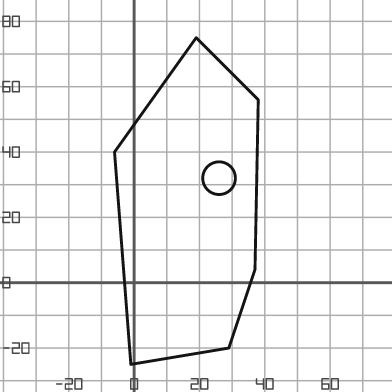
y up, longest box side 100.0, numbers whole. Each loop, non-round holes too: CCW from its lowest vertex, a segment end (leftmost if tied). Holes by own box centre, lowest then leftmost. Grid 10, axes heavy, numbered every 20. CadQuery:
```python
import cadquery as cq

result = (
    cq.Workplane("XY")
    .moveTo(-1.0, -25.0)
    .lineTo(29.0, -20.0)
    .lineTo(37.0, 4.0)
    .lineTo(38.0, 56.0)
    .lineTo(19.0, 75.0)
    .lineTo(-6.0, 40.0)
    .close()
    .moveTo(26.0, 32.0)
    .circle(5.0)
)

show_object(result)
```